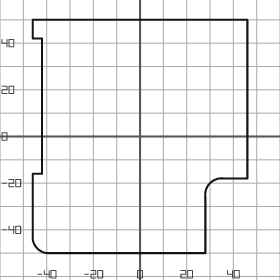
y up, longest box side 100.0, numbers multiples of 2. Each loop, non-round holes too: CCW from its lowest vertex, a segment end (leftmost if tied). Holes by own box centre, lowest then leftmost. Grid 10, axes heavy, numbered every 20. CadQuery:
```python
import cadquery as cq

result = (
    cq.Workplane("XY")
    .moveTo(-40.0, -50.0)
    .lineTo(28.0, -50.0)
    .lineTo(28.0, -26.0)
    .threePointArc((30.0, -20.0), (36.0, -18.0))
    .lineTo(46.0, -18.0)
    .lineTo(46.0, 50.0)
    .lineTo(-46.0, 50.0)
    .lineTo(-46.0, 42.0)
    .lineTo(-42.0, 42.0)
    .lineTo(-42.0, -16.0)
    .lineTo(-46.0, -16.0)
    .lineTo(-46.0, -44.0)
    .threePointArc((-44.0, -48.0), (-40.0, -50.0))
    .close()
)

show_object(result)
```